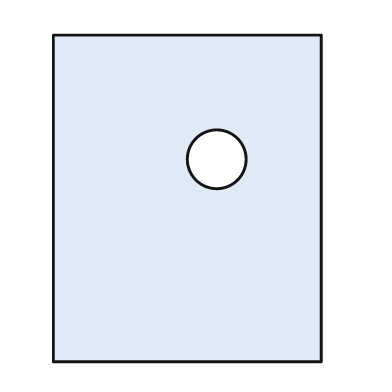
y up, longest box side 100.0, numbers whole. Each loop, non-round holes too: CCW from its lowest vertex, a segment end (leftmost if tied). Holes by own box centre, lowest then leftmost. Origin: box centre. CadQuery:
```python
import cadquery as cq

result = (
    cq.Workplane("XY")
    .moveTo(-41.0, -50.0)
    .lineTo(41.0, -50.0)
    .lineTo(41.0, 50.0)
    .lineTo(-41.0, 50.0)
    .close()
    .moveTo(9.0, 12.0)
    .circle(9.0)
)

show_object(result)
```